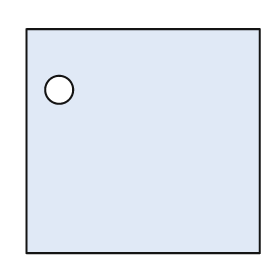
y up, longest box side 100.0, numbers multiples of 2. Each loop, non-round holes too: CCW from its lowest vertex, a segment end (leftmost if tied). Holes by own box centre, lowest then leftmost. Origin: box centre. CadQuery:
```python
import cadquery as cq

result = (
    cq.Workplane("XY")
    .moveTo(-50.0, -48.0)
    .lineTo(50.0, -48.0)
    .lineTo(50.0, 48.0)
    .lineTo(-50.0, 48.0)
    .close()
    .moveTo(-36.0, 22.0)
    .circle(6.0)
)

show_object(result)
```